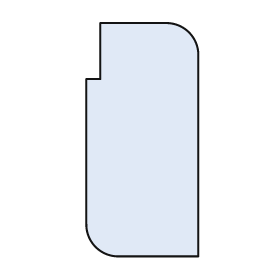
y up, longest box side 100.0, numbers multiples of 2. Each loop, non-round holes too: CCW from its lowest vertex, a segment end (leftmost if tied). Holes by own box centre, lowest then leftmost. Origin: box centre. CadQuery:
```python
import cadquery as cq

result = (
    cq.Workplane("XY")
    .moveTo(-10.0, -50.0)
    .lineTo(24.0, -50.0)
    .lineTo(24.0, 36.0)
    .threePointArc((20.0, 46.0), (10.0, 50.0))
    .lineTo(-18.0, 50.0)
    .lineTo(-18.0, 26.0)
    .lineTo(-24.0, 26.0)
    .lineTo(-24.0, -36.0)
    .threePointArc((-20.0, -46.0), (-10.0, -50.0))
    .close()
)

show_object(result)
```